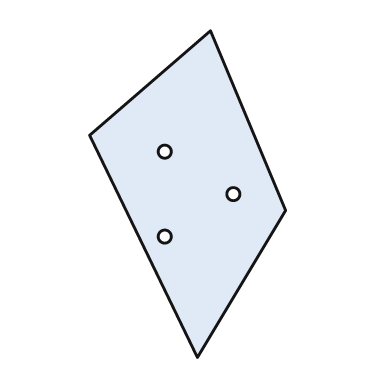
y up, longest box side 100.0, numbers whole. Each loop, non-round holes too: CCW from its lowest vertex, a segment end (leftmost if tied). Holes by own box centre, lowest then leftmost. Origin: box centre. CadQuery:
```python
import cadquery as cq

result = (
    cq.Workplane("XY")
    .moveTo(3.0, -50.0)
    .lineTo(30.0, -5.0)
    .lineTo(7.0, 50.0)
    .lineTo(-30.0, 18.0)
    .close()
    .moveTo(-7.0, -13.0)
    .circle(2.0)
    .moveTo(14.0, 0.0)
    .circle(2.0)
    .moveTo(-7.0, 13.0)
    .circle(2.0)
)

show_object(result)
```